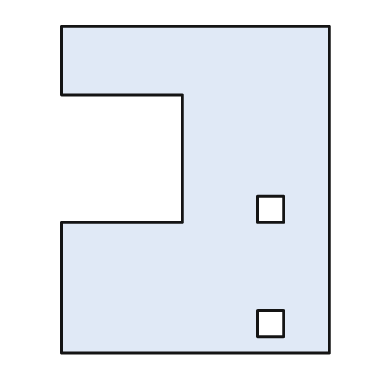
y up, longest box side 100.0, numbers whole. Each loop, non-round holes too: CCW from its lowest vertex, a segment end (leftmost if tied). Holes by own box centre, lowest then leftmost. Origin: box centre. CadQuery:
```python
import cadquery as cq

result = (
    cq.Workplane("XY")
    .moveTo(-41.0, -50.0)
    .lineTo(41.0, -50.0)
    .lineTo(41.0, 50.0)
    .lineTo(-41.0, 50.0)
    .lineTo(-41.0, 29.0)
    .lineTo(-4.0, 29.0)
    .lineTo(-4.0, -10.0)
    .lineTo(-41.0, -10.0)
    .close()
    .moveTo(19.0, -45.0)
    .lineTo(27.0, -45.0)
    .lineTo(27.0, -37.0)
    .lineTo(19.0, -37.0)
    .close()
    .moveTo(19.0, -10.0)
    .lineTo(27.0, -10.0)
    .lineTo(27.0, -2.0)
    .lineTo(19.0, -2.0)
    .close()
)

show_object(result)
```